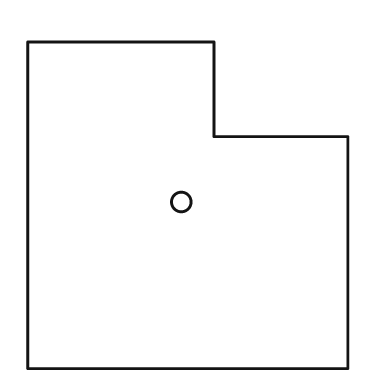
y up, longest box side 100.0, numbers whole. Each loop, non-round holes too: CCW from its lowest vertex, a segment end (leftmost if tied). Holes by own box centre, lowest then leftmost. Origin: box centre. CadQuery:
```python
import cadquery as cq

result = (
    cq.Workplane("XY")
    .moveTo(-49.0, -50.0)
    .lineTo(49.0, -50.0)
    .lineTo(49.0, 21.0)
    .lineTo(8.0, 21.0)
    .lineTo(8.0, 50.0)
    .lineTo(-49.0, 50.0)
    .close()
    .moveTo(-2.0, 1.0)
    .circle(3.0)
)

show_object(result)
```